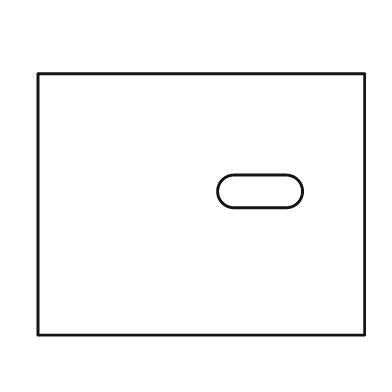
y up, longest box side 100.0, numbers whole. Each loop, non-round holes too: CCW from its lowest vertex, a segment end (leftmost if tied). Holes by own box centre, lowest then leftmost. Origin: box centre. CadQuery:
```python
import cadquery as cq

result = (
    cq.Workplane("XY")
    .moveTo(-50.0, -40.0)
    .lineTo(50.0, -40.0)
    .lineTo(50.0, 40.0)
    .lineTo(-50.0, 40.0)
    .close()
    .moveTo(10.0, -1.0)
    .lineTo(26.0, -1.0)
    .threePointArc((31.0, 4.0), (26.0, 9.0))
    .lineTo(10.0, 9.0)
    .threePointArc((5.0, 4.0), (10.0, -1.0))
    .close()
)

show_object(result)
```